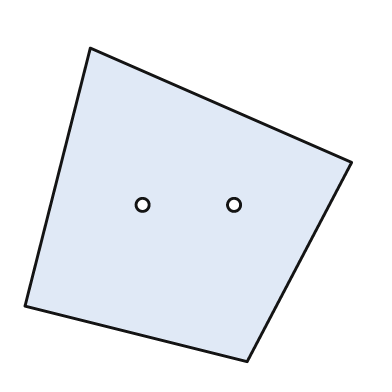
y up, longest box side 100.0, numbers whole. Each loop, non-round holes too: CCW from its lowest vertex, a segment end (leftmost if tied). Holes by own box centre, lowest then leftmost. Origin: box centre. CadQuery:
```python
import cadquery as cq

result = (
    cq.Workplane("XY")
    .moveTo(18.0, -48.0)
    .lineTo(50.0, 13.0)
    .lineTo(-30.0, 48.0)
    .lineTo(-50.0, -31.0)
    .close()
    .moveTo(-14.0, 0.0)
    .circle(2.0)
    .moveTo(14.0, 0.0)
    .circle(2.0)
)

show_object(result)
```